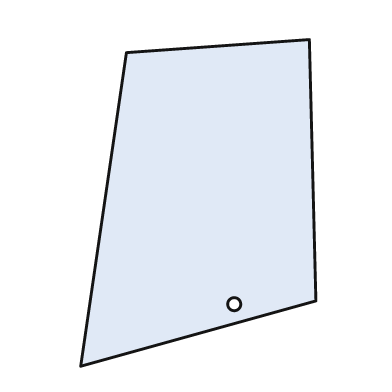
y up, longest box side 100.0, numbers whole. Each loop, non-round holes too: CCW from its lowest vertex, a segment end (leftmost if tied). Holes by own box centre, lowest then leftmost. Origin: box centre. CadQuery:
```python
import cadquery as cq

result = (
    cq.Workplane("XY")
    .moveTo(-36.0, -50.0)
    .lineTo(36.0, -30.0)
    .lineTo(34.0, 50.0)
    .lineTo(-22.0, 46.0)
    .close()
    .moveTo(11.0, -31.0)
    .circle(2.0)
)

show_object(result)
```